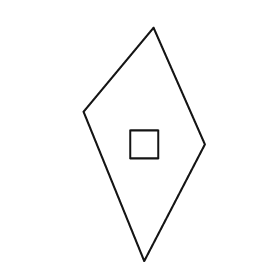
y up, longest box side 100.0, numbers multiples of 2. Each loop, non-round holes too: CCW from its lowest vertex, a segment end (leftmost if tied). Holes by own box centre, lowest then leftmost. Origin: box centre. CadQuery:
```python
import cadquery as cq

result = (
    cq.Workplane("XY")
    .moveTo(0.0, -50.0)
    .lineTo(26.0, 0.0)
    .lineTo(4.0, 50.0)
    .lineTo(-26.0, 14.0)
    .close()
    .moveTo(-6.0, -6.0)
    .lineTo(6.0, -6.0)
    .lineTo(6.0, 6.0)
    .lineTo(-6.0, 6.0)
    .close()
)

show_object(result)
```